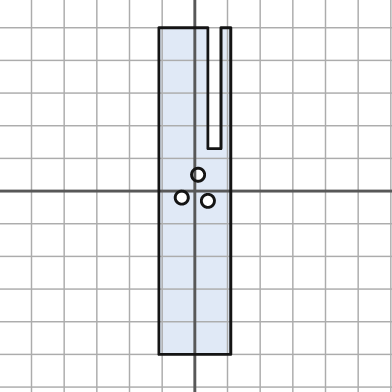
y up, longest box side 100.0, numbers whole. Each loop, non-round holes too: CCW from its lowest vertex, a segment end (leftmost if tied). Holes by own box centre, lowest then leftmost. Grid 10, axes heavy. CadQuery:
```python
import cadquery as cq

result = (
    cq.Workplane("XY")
    .moveTo(-11.0, -50.0)
    .lineTo(11.0, -50.0)
    .lineTo(11.0, 50.0)
    .lineTo(8.0, 50.0)
    .lineTo(8.0, 13.0)
    .lineTo(4.0, 13.0)
    .lineTo(4.0, 50.0)
    .lineTo(-11.0, 50.0)
    .close()
    .moveTo(4.0, -3.0)
    .circle(2.0)
    .moveTo(-4.0, -2.0)
    .circle(2.0)
    .moveTo(1.0, 5.0)
    .circle(2.0)
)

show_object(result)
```